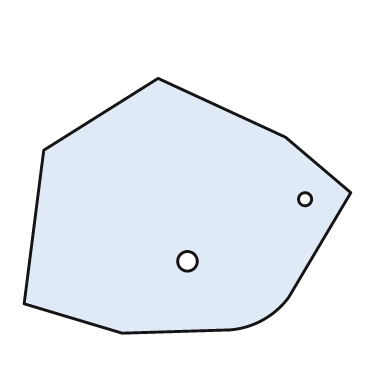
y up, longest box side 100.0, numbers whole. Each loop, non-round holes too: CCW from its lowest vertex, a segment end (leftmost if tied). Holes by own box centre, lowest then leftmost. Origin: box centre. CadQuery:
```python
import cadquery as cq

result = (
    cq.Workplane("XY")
    .moveTo(-20.0, -39.0)
    .lineTo(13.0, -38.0)
    .threePointArc((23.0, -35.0), (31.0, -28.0))
    .lineTo(50.0, 4.0)
    .lineTo(30.0, 21.0)
    .lineTo(-9.0, 39.0)
    .lineTo(-44.0, 17.0)
    .lineTo(-50.0, -30.0)
    .close()
    .moveTo(0.0, -17.0)
    .circle(3.0)
    .moveTo(36.0, 2.0)
    .circle(2.0)
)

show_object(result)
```